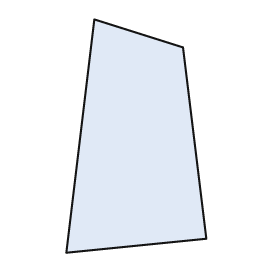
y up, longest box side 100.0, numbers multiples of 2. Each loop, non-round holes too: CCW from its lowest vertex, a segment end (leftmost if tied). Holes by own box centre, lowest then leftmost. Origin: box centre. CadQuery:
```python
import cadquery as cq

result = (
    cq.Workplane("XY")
    .moveTo(-30.0, -50.0)
    .lineTo(30.0, -44.0)
    .lineTo(20.0, 38.0)
    .lineTo(-18.0, 50.0)
    .close()
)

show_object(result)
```